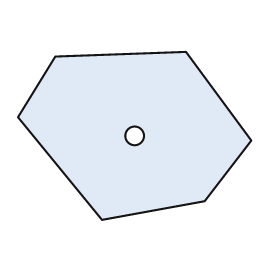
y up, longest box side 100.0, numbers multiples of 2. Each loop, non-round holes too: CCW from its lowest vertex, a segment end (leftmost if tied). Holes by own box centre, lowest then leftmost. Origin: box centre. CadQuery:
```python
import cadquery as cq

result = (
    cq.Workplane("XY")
    .moveTo(-14.0, -36.0)
    .lineTo(30.0, -28.0)
    .lineTo(50.0, -2.0)
    .lineTo(22.0, 36.0)
    .lineTo(-34.0, 34.0)
    .lineTo(-50.0, 8.0)
    .close()
    .moveTo(0.0, 0.0)
    .circle(4.0)
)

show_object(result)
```